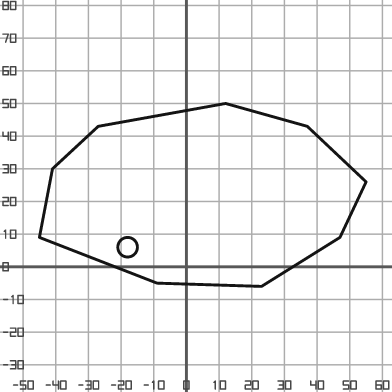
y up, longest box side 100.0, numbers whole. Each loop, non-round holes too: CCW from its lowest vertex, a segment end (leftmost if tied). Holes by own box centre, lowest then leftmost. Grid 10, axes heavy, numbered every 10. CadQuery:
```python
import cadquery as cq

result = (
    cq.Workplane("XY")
    .moveTo(23.0, -6.0)
    .lineTo(47.0, 9.0)
    .lineTo(55.0, 26.0)
    .lineTo(37.0, 43.0)
    .lineTo(12.0, 50.0)
    .lineTo(-27.0, 43.0)
    .lineTo(-41.0, 30.0)
    .lineTo(-45.0, 9.0)
    .lineTo(-9.0, -5.0)
    .close()
    .moveTo(-18.0, 6.0)
    .circle(3.0)
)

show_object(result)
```